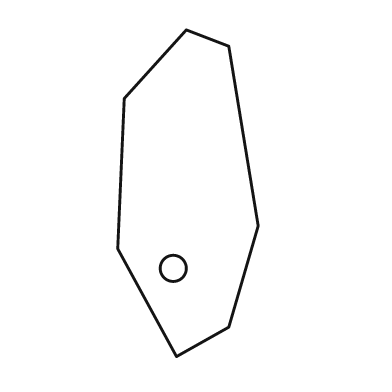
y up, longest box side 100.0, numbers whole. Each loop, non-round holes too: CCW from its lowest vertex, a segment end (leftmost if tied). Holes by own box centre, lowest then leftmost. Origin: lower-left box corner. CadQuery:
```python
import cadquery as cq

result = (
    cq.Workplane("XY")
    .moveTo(18.0, 0.0)
    .lineTo(34.0, 9.0)
    .lineTo(43.0, 40.0)
    .lineTo(34.0, 95.0)
    .lineTo(21.0, 100.0)
    .lineTo(2.0, 79.0)
    .lineTo(0.0, 33.0)
    .close()
    .moveTo(17.0, 27.0)
    .circle(4.0)
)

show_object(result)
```